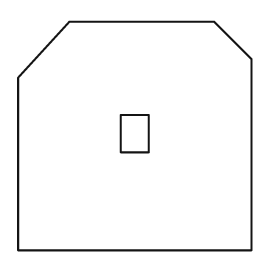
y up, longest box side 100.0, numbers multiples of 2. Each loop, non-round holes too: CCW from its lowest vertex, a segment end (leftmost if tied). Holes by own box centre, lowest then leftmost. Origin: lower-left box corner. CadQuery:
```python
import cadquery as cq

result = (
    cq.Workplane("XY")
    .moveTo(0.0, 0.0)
    .lineTo(100.0, 0.0)
    .lineTo(100.0, 82.0)
    .lineTo(84.0, 98.0)
    .lineTo(22.0, 98.0)
    .lineTo(0.0, 74.0)
    .close()
    .moveTo(44.0, 42.0)
    .lineTo(56.0, 42.0)
    .lineTo(56.0, 58.0)
    .lineTo(44.0, 58.0)
    .close()
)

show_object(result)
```